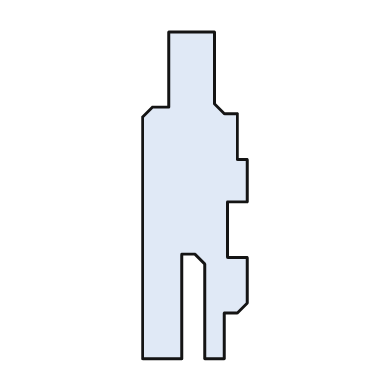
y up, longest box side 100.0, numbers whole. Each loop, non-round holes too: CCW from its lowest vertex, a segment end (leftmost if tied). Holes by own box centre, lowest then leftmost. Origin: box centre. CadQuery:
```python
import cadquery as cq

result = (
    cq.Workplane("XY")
    .moveTo(-16.0, -50.0)
    .lineTo(-4.0, -50.0)
    .lineTo(-4.0, -18.0)
    .lineTo(0.0, -18.0)
    .lineTo(3.0, -21.0)
    .lineTo(3.0, -50.0)
    .lineTo(9.0, -50.0)
    .lineTo(9.0, -36.0)
    .lineTo(13.0, -36.0)
    .lineTo(16.0, -33.0)
    .lineTo(16.0, -19.0)
    .lineTo(10.0, -19.0)
    .lineTo(10.0, -2.0)
    .lineTo(16.0, -2.0)
    .lineTo(16.0, 11.0)
    .lineTo(13.0, 11.0)
    .lineTo(13.0, 25.0)
    .lineTo(9.0, 25.0)
    .lineTo(6.0, 28.0)
    .lineTo(6.0, 50.0)
    .lineTo(-8.0, 50.0)
    .lineTo(-8.0, 27.0)
    .lineTo(-13.0, 27.0)
    .lineTo(-16.0, 24.0)
    .close()
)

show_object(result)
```